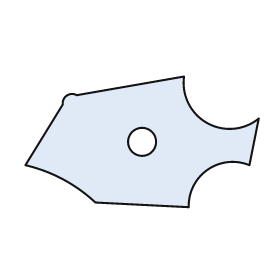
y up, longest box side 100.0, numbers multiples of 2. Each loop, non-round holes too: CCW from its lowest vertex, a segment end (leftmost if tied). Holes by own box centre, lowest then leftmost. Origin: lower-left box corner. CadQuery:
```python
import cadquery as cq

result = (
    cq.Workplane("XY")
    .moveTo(70.0, 0.0)
    .threePointArc((78.0, 16.0), (96.0, 18.0))
    .lineTo(100.0, 38.0)
    .threePointArc((78.0, 36.0), (68.0, 56.0))
    .lineTo(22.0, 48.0)
    .threePointArc((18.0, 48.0), (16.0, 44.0))
    .lineTo(0.0, 18.0)
    .threePointArc((16.0, 12.0), (30.0, 2.0))
    .close()
    .moveTo(50.0, 28.0)
    .circle(6.0)
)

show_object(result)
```